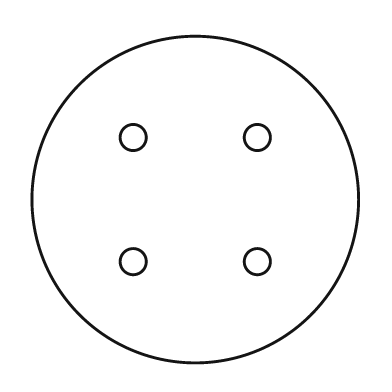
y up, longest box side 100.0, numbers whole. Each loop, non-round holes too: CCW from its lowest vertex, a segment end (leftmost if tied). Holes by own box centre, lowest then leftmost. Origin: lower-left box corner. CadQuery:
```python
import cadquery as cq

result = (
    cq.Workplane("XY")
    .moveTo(50.0, 50.0)
    .circle(50.0)
    .moveTo(31.0, 31.0)
    .circle(4.0)
    .moveTo(69.0, 31.0)
    .circle(4.0)
    .moveTo(31.0, 69.0)
    .circle(4.0)
    .moveTo(69.0, 69.0)
    .circle(4.0)
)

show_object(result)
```